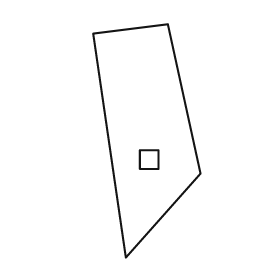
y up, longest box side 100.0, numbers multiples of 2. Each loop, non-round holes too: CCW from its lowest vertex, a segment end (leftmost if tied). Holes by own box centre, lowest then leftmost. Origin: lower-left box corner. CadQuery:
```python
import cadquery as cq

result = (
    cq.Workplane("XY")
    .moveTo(14.0, 0.0)
    .lineTo(46.0, 36.0)
    .lineTo(32.0, 100.0)
    .lineTo(0.0, 96.0)
    .close()
    .moveTo(20.0, 38.0)
    .lineTo(28.0, 38.0)
    .lineTo(28.0, 46.0)
    .lineTo(20.0, 46.0)
    .close()
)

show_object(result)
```